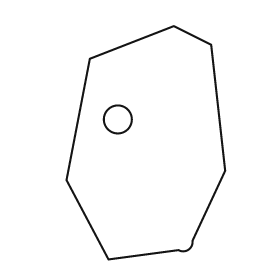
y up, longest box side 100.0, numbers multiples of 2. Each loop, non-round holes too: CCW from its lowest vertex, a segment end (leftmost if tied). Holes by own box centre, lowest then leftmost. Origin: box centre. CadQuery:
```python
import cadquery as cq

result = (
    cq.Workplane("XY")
    .moveTo(-16.0, -50.0)
    .lineTo(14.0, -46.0)
    .threePointArc((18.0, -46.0), (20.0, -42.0))
    .lineTo(34.0, -12.0)
    .lineTo(28.0, 42.0)
    .lineTo(12.0, 50.0)
    .lineTo(-24.0, 36.0)
    .lineTo(-34.0, -16.0)
    .close()
    .moveTo(-12.0, 10.0)
    .circle(6.0)
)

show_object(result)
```